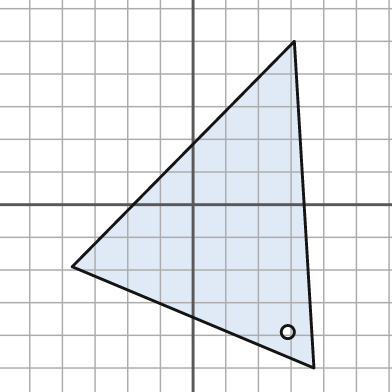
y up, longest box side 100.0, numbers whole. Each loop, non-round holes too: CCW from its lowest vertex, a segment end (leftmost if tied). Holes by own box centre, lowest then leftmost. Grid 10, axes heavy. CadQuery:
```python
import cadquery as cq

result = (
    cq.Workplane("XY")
    .moveTo(37.0, -50.0)
    .lineTo(31.0, 50.0)
    .lineTo(-37.0, -19.0)
    .close()
    .moveTo(29.0, -39.0)
    .circle(2.0)
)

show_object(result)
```